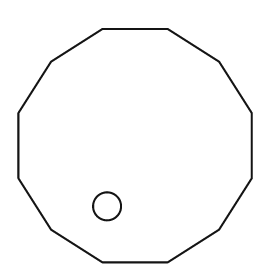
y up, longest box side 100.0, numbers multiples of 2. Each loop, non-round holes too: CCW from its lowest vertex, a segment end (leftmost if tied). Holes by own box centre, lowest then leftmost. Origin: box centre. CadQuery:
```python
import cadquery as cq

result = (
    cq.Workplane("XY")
    .moveTo(-14.0, -50.0)
    .lineTo(14.0, -50.0)
    .lineTo(36.0, -36.0)
    .lineTo(50.0, -14.0)
    .lineTo(50.0, 14.0)
    .lineTo(36.0, 36.0)
    .lineTo(14.0, 50.0)
    .lineTo(-14.0, 50.0)
    .lineTo(-36.0, 36.0)
    .lineTo(-50.0, 14.0)
    .lineTo(-50.0, -14.0)
    .lineTo(-36.0, -36.0)
    .close()
    .moveTo(-12.0, -26.0)
    .circle(6.0)
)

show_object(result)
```